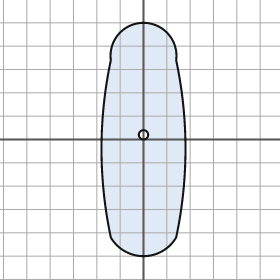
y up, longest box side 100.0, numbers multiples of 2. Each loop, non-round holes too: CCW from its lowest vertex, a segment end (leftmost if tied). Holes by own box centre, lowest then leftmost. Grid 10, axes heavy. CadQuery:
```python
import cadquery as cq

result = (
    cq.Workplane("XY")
    .moveTo(-14.0, -42.0)
    .threePointArc((0.0, -50.0), (14.0, -42.0))
    .threePointArc((18.0, -4.0), (14.0, 34.0))
    .threePointArc((0.0, 50.0), (-14.0, 34.0))
    .threePointArc((-18.0, -4.0), (-14.0, -42.0))
    .close()
    .moveTo(0.0, 2.0)
    .circle(2.0)
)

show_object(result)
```